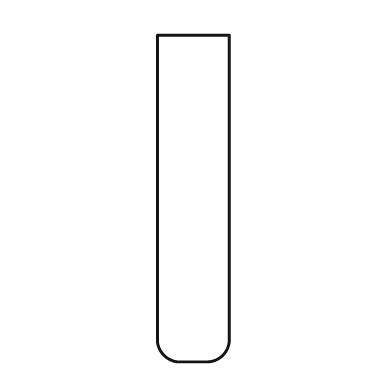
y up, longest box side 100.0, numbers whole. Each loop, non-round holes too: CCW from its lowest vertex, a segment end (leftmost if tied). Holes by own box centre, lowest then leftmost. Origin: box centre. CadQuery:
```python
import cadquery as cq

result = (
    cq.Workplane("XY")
    .moveTo(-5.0, -50.0)
    .lineTo(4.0, -50.0)
    .threePointArc((9.0, -48.0), (11.0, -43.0))
    .lineTo(11.0, 50.0)
    .lineTo(-11.0, 50.0)
    .lineTo(-11.0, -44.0)
    .threePointArc((-9.0, -48.0), (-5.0, -50.0))
    .close()
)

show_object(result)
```